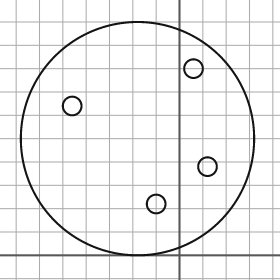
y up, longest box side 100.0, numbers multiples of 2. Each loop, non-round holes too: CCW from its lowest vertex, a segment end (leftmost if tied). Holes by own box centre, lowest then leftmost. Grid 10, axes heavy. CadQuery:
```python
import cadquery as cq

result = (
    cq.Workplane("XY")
    .moveTo(-18.0, 50.0)
    .circle(50.0)
    .moveTo(-10.0, 22.0)
    .circle(4.0)
    .moveTo(12.0, 38.0)
    .circle(4.0)
    .moveTo(-46.0, 64.0)
    .circle(4.0)
    .moveTo(6.0, 80.0)
    .circle(4.0)
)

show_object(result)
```